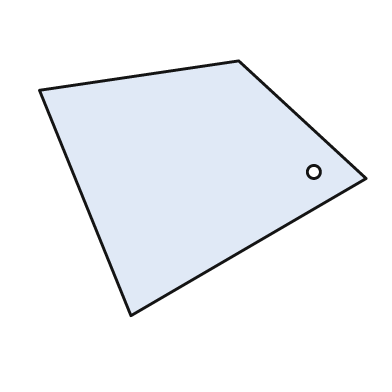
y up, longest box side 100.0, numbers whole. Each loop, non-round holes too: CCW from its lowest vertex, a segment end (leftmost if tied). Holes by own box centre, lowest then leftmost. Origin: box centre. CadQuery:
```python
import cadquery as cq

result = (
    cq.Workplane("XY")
    .moveTo(-22.0, -39.0)
    .lineTo(50.0, 3.0)
    .lineTo(11.0, 39.0)
    .lineTo(-50.0, 30.0)
    .close()
    .moveTo(34.0, 5.0)
    .circle(2.0)
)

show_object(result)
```